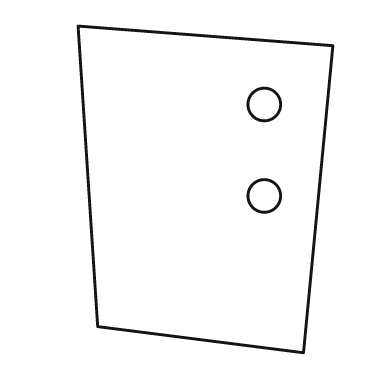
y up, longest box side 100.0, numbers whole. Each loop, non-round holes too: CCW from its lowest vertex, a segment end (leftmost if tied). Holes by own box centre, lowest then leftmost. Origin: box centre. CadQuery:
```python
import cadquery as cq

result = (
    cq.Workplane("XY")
    .moveTo(30.0, -50.0)
    .lineTo(39.0, 44.0)
    .lineTo(-39.0, 50.0)
    .lineTo(-33.0, -42.0)
    .close()
    .moveTo(18.0, -2.0)
    .circle(5.0)
    .moveTo(18.0, 26.0)
    .circle(5.0)
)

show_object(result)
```